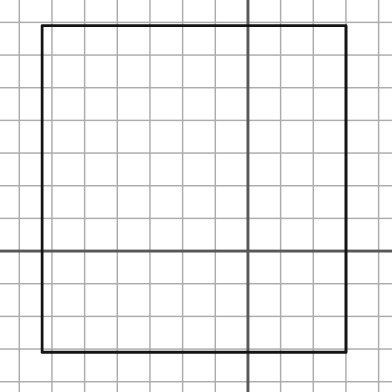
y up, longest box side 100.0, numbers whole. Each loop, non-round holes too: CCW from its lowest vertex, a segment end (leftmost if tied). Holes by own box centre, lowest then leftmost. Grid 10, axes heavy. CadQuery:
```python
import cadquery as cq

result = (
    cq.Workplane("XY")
    .moveTo(-63.0, -31.0)
    .lineTo(30.0, -31.0)
    .lineTo(30.0, 69.0)
    .lineTo(-63.0, 69.0)
    .close()
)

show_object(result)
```